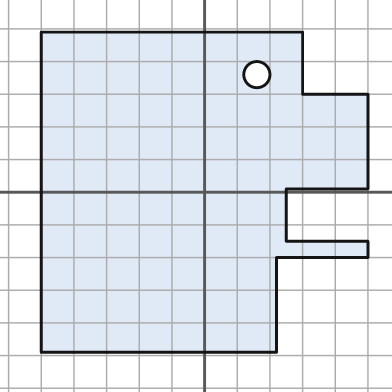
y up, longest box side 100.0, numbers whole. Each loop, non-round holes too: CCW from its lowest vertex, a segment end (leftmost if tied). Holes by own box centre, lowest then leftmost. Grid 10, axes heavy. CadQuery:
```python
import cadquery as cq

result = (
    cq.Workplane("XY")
    .moveTo(-50.0, -49.0)
    .lineTo(22.0, -49.0)
    .lineTo(22.0, -20.0)
    .lineTo(50.0, -20.0)
    .lineTo(50.0, -15.0)
    .lineTo(25.0, -15.0)
    .lineTo(25.0, 1.0)
    .lineTo(50.0, 1.0)
    .lineTo(50.0, 30.0)
    .lineTo(30.0, 30.0)
    .lineTo(30.0, 49.0)
    .lineTo(-50.0, 49.0)
    .close()
    .moveTo(16.0, 36.0)
    .circle(4.0)
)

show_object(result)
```